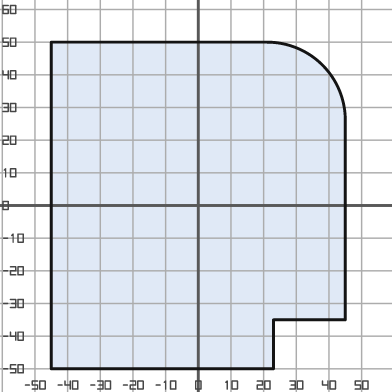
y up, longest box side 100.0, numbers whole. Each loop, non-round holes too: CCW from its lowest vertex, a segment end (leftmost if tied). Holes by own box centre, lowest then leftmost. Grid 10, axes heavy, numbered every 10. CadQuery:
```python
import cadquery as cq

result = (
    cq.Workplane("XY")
    .moveTo(-45.0, -50.0)
    .lineTo(23.0, -50.0)
    .lineTo(23.0, -35.0)
    .lineTo(45.0, -35.0)
    .lineTo(45.0, 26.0)
    .threePointArc((38.0, 43.0), (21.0, 50.0))
    .lineTo(-45.0, 50.0)
    .close()
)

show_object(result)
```